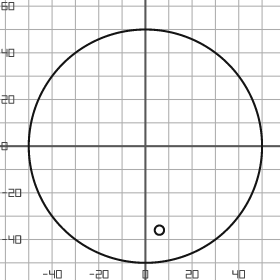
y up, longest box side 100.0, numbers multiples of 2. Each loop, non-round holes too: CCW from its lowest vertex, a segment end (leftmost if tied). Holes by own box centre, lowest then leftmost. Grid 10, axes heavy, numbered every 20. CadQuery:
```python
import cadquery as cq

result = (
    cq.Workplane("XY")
    .moveTo(0.0, 0.0)
    .circle(50.0)
    .moveTo(6.0, -36.0)
    .circle(2.0)
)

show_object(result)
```